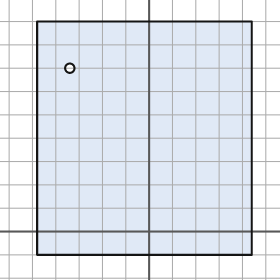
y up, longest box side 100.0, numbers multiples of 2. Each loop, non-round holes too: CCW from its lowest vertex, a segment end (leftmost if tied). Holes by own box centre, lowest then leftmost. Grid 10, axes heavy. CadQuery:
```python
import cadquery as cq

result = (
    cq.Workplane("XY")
    .moveTo(-48.0, -10.0)
    .lineTo(44.0, -10.0)
    .lineTo(44.0, 90.0)
    .lineTo(-48.0, 90.0)
    .close()
    .moveTo(-34.0, 70.0)
    .circle(2.0)
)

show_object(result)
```